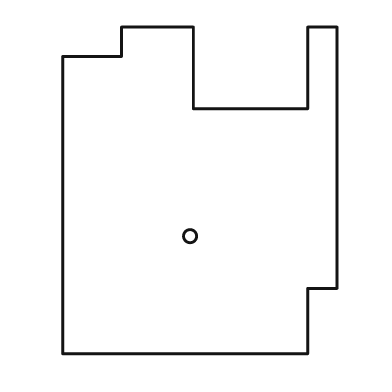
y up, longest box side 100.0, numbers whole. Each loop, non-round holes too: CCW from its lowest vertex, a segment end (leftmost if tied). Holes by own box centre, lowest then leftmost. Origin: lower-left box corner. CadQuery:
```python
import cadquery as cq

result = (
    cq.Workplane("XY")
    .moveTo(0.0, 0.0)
    .lineTo(75.0, 0.0)
    .lineTo(75.0, 20.0)
    .lineTo(84.0, 20.0)
    .lineTo(84.0, 100.0)
    .lineTo(75.0, 100.0)
    .lineTo(75.0, 75.0)
    .lineTo(40.0, 75.0)
    .lineTo(40.0, 100.0)
    .lineTo(18.0, 100.0)
    .lineTo(18.0, 91.0)
    .lineTo(0.0, 91.0)
    .close()
    .moveTo(39.0, 36.0)
    .circle(2.0)
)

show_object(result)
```